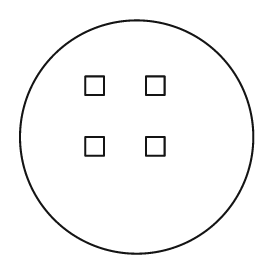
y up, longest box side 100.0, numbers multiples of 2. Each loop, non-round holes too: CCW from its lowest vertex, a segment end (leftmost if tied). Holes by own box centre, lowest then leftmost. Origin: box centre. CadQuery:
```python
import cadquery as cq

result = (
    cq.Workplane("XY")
    .moveTo(0.0, 0.0)
    .circle(50.0)
    .moveTo(-22.0, -8.0)
    .lineTo(-14.0, -8.0)
    .lineTo(-14.0, 0.0)
    .lineTo(-22.0, 0.0)
    .close()
    .moveTo(4.0, -8.0)
    .lineTo(12.0, -8.0)
    .lineTo(12.0, 0.0)
    .lineTo(4.0, 0.0)
    .close()
    .moveTo(-22.0, 18.0)
    .lineTo(-14.0, 18.0)
    .lineTo(-14.0, 26.0)
    .lineTo(-22.0, 26.0)
    .close()
    .moveTo(4.0, 18.0)
    .lineTo(12.0, 18.0)
    .lineTo(12.0, 26.0)
    .lineTo(4.0, 26.0)
    .close()
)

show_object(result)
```